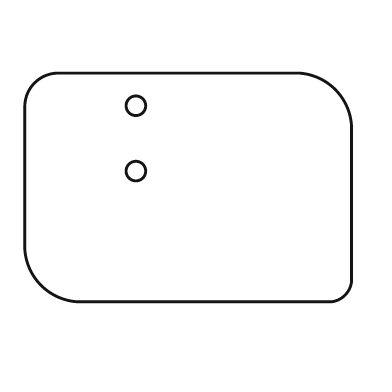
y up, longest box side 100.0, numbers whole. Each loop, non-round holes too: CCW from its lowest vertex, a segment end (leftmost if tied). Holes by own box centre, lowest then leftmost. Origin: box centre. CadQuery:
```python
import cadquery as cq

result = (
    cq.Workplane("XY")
    .moveTo(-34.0, -35.0)
    .lineTo(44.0, -35.0)
    .threePointArc((48.0, -33.0), (50.0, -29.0))
    .lineTo(50.0, 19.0)
    .threePointArc((45.0, 30.0), (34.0, 35.0))
    .lineTo(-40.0, 35.0)
    .threePointArc((-47.0, 32.0), (-50.0, 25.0))
    .lineTo(-50.0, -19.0)
    .threePointArc((-45.0, -30.0), (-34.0, -35.0))
    .close()
    .moveTo(-16.0, 5.0)
    .circle(3.0)
    .moveTo(-16.0, 25.0)
    .circle(3.0)
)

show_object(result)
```